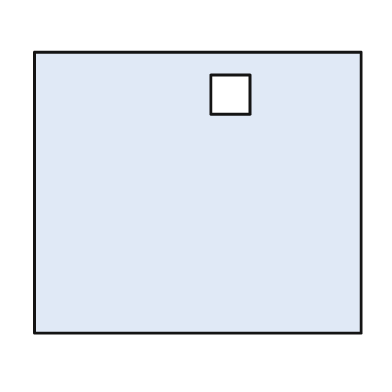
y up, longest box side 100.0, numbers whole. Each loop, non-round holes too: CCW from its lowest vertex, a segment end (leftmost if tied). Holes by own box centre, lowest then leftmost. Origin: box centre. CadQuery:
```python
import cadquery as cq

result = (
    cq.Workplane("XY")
    .moveTo(-50.0, -43.0)
    .lineTo(50.0, -43.0)
    .lineTo(50.0, 43.0)
    .lineTo(-50.0, 43.0)
    .close()
    .moveTo(4.0, 24.0)
    .lineTo(16.0, 24.0)
    .lineTo(16.0, 36.0)
    .lineTo(4.0, 36.0)
    .close()
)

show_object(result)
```